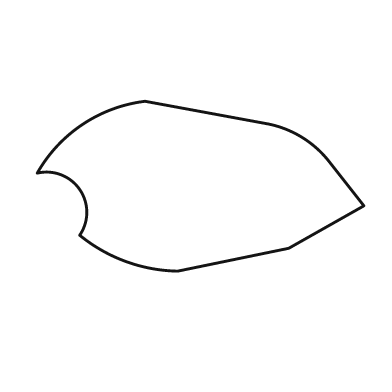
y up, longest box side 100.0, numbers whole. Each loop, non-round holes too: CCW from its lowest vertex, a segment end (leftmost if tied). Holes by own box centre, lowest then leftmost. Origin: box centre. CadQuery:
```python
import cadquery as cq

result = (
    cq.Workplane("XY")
    .moveTo(-7.0, -26.0)
    .lineTo(27.0, -19.0)
    .lineTo(50.0, -6.0)
    .lineTo(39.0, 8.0)
    .threePointArc((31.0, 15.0), (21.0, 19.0))
    .lineTo(-17.0, 26.0)
    .threePointArc((-36.0, 19.0), (-50.0, 4.0))
    .threePointArc((-37.0, -1.0), (-37.0, -15.0))
    .threePointArc((-23.0, -23.0), (-7.0, -26.0))
    .close()
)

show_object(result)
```